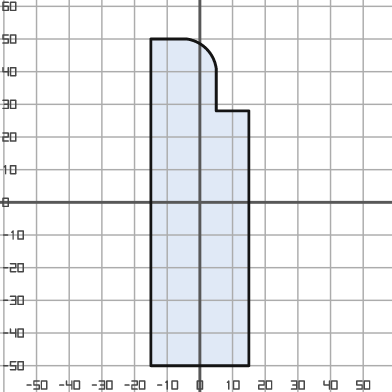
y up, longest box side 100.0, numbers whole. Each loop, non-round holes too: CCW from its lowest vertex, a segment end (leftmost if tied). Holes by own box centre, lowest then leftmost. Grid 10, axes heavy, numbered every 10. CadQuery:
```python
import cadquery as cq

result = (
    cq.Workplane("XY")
    .moveTo(-15.0, -50.0)
    .lineTo(15.0, -50.0)
    .lineTo(15.0, 28.0)
    .lineTo(5.0, 28.0)
    .lineTo(5.0, 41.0)
    .threePointArc((2.0, 47.0), (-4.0, 50.0))
    .lineTo(-15.0, 50.0)
    .close()
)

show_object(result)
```